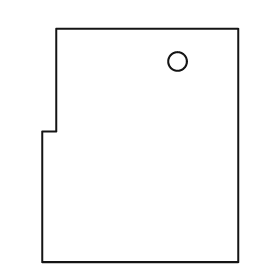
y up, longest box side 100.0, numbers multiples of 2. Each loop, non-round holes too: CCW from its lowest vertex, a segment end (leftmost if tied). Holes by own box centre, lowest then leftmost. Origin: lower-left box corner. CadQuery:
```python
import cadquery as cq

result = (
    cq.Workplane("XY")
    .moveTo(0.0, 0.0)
    .lineTo(84.0, 0.0)
    .lineTo(84.0, 100.0)
    .lineTo(6.0, 100.0)
    .lineTo(6.0, 56.0)
    .lineTo(0.0, 56.0)
    .close()
    .moveTo(58.0, 86.0)
    .circle(4.0)
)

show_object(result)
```